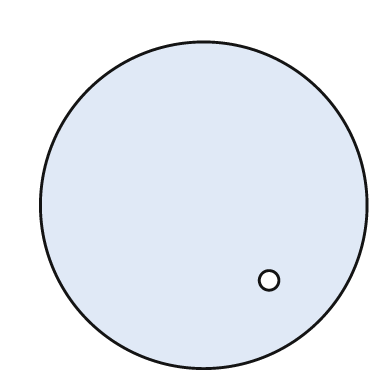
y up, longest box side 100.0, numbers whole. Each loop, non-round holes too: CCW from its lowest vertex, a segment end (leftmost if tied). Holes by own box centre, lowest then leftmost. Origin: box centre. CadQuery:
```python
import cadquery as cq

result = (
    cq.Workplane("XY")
    .moveTo(0.0, 0.0)
    .circle(50.0)
    .moveTo(20.0, -23.0)
    .circle(3.0)
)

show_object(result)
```